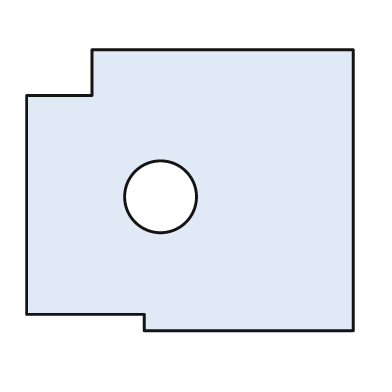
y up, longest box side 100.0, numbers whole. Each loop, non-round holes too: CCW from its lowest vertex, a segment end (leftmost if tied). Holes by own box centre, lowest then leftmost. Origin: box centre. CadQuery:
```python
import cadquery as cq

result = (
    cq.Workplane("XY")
    .moveTo(-14.0, -43.0)
    .lineTo(50.0, -43.0)
    .lineTo(50.0, 43.0)
    .lineTo(-30.0, 43.0)
    .lineTo(-30.0, 29.0)
    .lineTo(-50.0, 29.0)
    .lineTo(-50.0, -38.0)
    .lineTo(-14.0, -38.0)
    .close()
    .moveTo(-9.0, -2.0)
    .circle(11.0)
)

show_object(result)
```